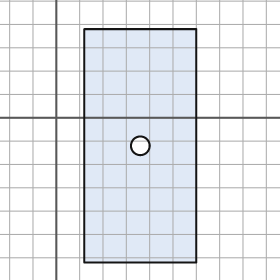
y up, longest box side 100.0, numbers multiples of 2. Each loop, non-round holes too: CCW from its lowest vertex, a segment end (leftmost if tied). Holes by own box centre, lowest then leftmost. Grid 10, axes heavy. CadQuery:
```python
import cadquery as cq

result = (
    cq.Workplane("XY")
    .moveTo(12.0, -62.0)
    .lineTo(60.0, -62.0)
    .lineTo(60.0, 38.0)
    .lineTo(12.0, 38.0)
    .close()
    .moveTo(36.0, -12.0)
    .circle(4.0)
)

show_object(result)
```